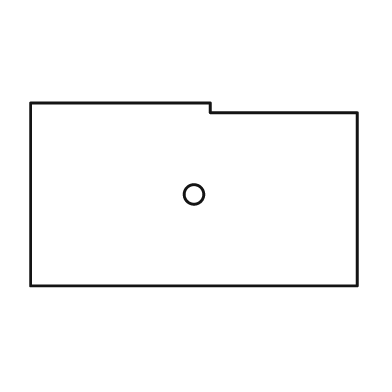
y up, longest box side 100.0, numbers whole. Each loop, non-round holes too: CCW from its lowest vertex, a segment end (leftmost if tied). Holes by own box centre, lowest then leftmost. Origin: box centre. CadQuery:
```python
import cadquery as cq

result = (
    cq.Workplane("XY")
    .moveTo(-50.0, -28.0)
    .lineTo(50.0, -28.0)
    .lineTo(50.0, 25.0)
    .lineTo(5.0, 25.0)
    .lineTo(5.0, 28.0)
    .lineTo(-50.0, 28.0)
    .close()
    .moveTo(0.0, 0.0)
    .circle(3.0)
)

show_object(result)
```